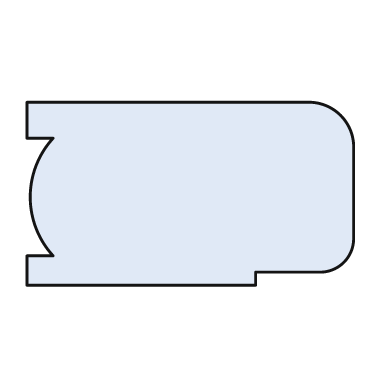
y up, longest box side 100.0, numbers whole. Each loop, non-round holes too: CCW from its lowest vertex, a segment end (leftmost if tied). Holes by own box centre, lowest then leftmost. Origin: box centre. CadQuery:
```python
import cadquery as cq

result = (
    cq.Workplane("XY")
    .moveTo(-50.0, -28.0)
    .lineTo(20.0, -28.0)
    .lineTo(20.0, -24.0)
    .lineTo(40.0, -24.0)
    .threePointArc((47.0, -21.0), (50.0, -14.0))
    .lineTo(50.0, 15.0)
    .threePointArc((46.0, 24.0), (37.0, 28.0))
    .lineTo(-50.0, 28.0)
    .lineTo(-50.0, 17.0)
    .lineTo(-42.0, 17.0)
    .threePointArc((-49.0, -1.0), (-42.0, -19.0))
    .lineTo(-50.0, -19.0)
    .close()
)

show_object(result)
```